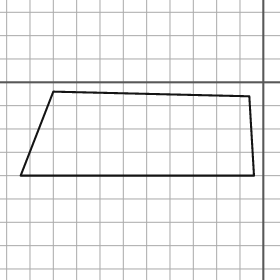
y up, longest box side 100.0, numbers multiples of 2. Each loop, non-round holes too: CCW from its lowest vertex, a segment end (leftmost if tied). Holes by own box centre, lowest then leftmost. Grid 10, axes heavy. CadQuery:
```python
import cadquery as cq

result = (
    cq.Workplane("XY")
    .moveTo(-104.0, -40.0)
    .lineTo(-4.0, -40.0)
    .lineTo(-6.0, -6.0)
    .lineTo(-90.0, -4.0)
    .close()
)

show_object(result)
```